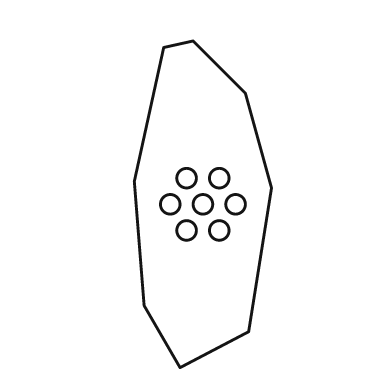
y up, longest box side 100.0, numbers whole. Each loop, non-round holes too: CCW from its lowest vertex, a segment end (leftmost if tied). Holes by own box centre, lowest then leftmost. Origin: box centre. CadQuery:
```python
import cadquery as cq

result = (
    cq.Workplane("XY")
    .moveTo(-7.0, -50.0)
    .lineTo(14.0, -39.0)
    .lineTo(21.0, 5.0)
    .lineTo(13.0, 34.0)
    .lineTo(-3.0, 50.0)
    .lineTo(-12.0, 48.0)
    .lineTo(-21.0, 7.0)
    .lineTo(-18.0, -31.0)
    .close()
    .moveTo(-5.0, -8.0)
    .circle(3.0)
    .moveTo(5.0, -8.0)
    .circle(3.0)
    .moveTo(-10.0, 0.0)
    .circle(3.0)
    .moveTo(0.0, 0.0)
    .circle(3.0)
    .moveTo(10.0, 0.0)
    .circle(3.0)
    .moveTo(-5.0, 8.0)
    .circle(3.0)
    .moveTo(5.0, 8.0)
    .circle(3.0)
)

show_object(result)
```